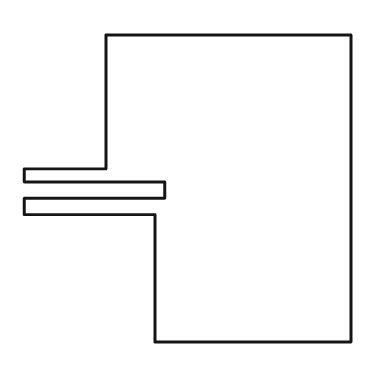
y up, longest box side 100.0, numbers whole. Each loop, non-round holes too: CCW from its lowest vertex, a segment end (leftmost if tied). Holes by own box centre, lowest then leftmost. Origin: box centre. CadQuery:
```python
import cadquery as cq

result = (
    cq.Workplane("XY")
    .moveTo(-10.0, -47.0)
    .lineTo(50.0, -47.0)
    .lineTo(50.0, 47.0)
    .lineTo(-25.0, 47.0)
    .lineTo(-25.0, 6.0)
    .lineTo(-50.0, 6.0)
    .lineTo(-50.0, 2.0)
    .lineTo(-7.0, 2.0)
    .lineTo(-7.0, -3.0)
    .lineTo(-50.0, -3.0)
    .lineTo(-50.0, -8.0)
    .lineTo(-10.0, -8.0)
    .close()
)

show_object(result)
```